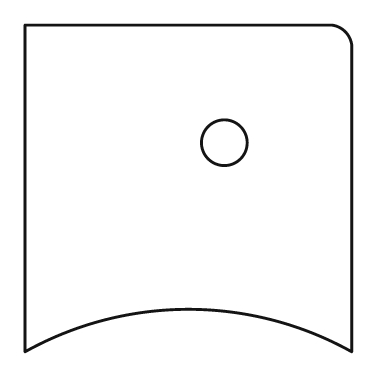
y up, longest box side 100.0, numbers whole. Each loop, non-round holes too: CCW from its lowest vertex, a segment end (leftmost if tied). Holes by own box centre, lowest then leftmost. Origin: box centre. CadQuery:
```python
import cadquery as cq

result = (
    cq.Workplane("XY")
    .moveTo(-50.0, -50.0)
    .threePointArc((0.0, -37.0), (50.0, -50.0))
    .lineTo(50.0, 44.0)
    .threePointArc((48.0, 48.0), (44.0, 50.0))
    .lineTo(-50.0, 50.0)
    .close()
    .moveTo(11.0, 14.0)
    .circle(7.0)
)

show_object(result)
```